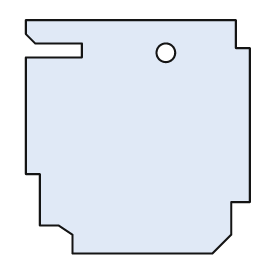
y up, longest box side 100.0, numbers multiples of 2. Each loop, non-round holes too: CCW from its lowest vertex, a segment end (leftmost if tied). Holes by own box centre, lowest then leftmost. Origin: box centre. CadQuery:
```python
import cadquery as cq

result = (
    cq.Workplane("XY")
    .moveTo(-28.0, -50.0)
    .lineTo(32.0, -50.0)
    .lineTo(40.0, -42.0)
    .lineTo(40.0, -28.0)
    .lineTo(48.0, -28.0)
    .lineTo(48.0, 38.0)
    .lineTo(42.0, 38.0)
    .lineTo(42.0, 50.0)
    .lineTo(-48.0, 50.0)
    .lineTo(-48.0, 44.0)
    .lineTo(-44.0, 40.0)
    .lineTo(-24.0, 40.0)
    .lineTo(-24.0, 34.0)
    .lineTo(-48.0, 34.0)
    .lineTo(-48.0, -16.0)
    .lineTo(-42.0, -16.0)
    .lineTo(-42.0, -38.0)
    .lineTo(-34.0, -38.0)
    .lineTo(-28.0, -42.0)
    .close()
    .moveTo(12.0, 36.0)
    .circle(4.0)
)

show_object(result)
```